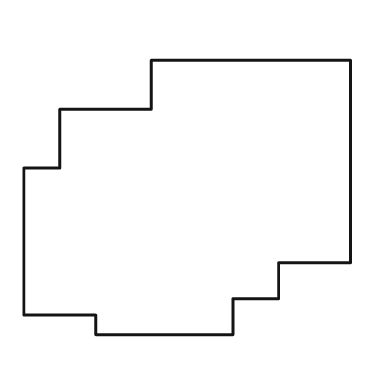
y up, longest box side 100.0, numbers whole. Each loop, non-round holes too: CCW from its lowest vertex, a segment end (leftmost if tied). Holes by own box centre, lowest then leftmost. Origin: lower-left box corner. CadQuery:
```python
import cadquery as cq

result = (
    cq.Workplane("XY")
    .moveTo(22.0, 0.0)
    .lineTo(64.0, 0.0)
    .lineTo(64.0, 11.0)
    .lineTo(78.0, 11.0)
    .lineTo(78.0, 22.0)
    .lineTo(100.0, 22.0)
    .lineTo(100.0, 84.0)
    .lineTo(39.0, 84.0)
    .lineTo(39.0, 69.0)
    .lineTo(11.0, 69.0)
    .lineTo(11.0, 51.0)
    .lineTo(0.0, 51.0)
    .lineTo(0.0, 6.0)
    .lineTo(22.0, 6.0)
    .close()
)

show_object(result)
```